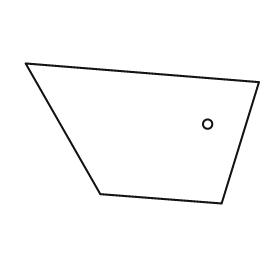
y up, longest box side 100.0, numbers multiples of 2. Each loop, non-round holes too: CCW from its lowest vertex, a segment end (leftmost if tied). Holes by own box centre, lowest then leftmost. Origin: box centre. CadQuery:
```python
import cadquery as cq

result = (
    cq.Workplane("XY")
    .moveTo(34.0, -30.0)
    .lineTo(50.0, 22.0)
    .lineTo(-50.0, 30.0)
    .lineTo(-18.0, -26.0)
    .close()
    .moveTo(28.0, 4.0)
    .circle(2.0)
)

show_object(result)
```